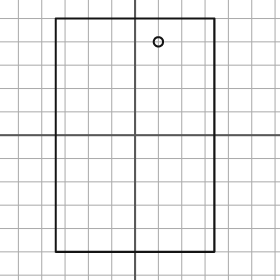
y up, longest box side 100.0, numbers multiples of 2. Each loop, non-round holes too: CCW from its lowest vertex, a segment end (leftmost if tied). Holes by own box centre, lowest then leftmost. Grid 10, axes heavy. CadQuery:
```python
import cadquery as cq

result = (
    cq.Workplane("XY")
    .moveTo(-34.0, -50.0)
    .lineTo(34.0, -50.0)
    .lineTo(34.0, 50.0)
    .lineTo(-34.0, 50.0)
    .close()
    .moveTo(10.0, 40.0)
    .circle(2.0)
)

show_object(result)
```